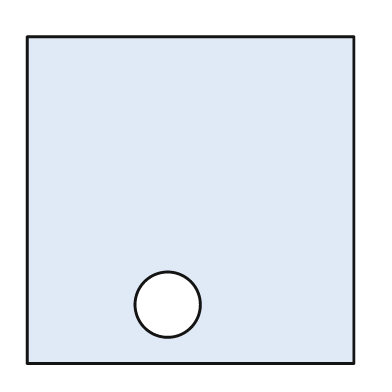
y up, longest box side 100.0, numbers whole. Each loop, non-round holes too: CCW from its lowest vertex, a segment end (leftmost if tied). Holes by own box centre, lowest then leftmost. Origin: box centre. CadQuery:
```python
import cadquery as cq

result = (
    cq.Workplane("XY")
    .moveTo(-50.0, -50.0)
    .lineTo(50.0, -50.0)
    .lineTo(50.0, 50.0)
    .lineTo(-50.0, 50.0)
    .close()
    .moveTo(-7.0, -32.0)
    .circle(10.0)
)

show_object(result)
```